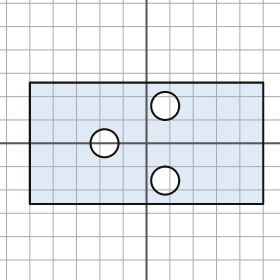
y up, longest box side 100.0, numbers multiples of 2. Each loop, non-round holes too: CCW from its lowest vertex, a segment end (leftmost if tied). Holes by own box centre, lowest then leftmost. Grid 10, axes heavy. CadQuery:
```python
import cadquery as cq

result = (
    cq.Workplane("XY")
    .moveTo(-50.0, -26.0)
    .lineTo(50.0, -26.0)
    .lineTo(50.0, 26.0)
    .lineTo(-50.0, 26.0)
    .close()
    .moveTo(8.0, -16.0)
    .circle(6.0)
    .moveTo(-18.0, 0.0)
    .circle(6.0)
    .moveTo(8.0, 16.0)
    .circle(6.0)
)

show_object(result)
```